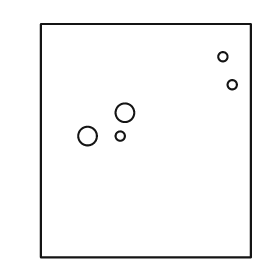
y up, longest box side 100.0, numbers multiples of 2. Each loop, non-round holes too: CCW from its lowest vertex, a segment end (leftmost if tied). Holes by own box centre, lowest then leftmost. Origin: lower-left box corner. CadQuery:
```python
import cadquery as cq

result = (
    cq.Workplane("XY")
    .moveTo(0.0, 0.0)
    .lineTo(90.0, 0.0)
    .lineTo(90.0, 100.0)
    .lineTo(0.0, 100.0)
    .close()
    .moveTo(20.0, 52.0)
    .circle(4.0)
    .moveTo(34.0, 52.0)
    .circle(2.0)
    .moveTo(36.0, 62.0)
    .circle(4.0)
    .moveTo(82.0, 74.0)
    .circle(2.0)
    .moveTo(78.0, 86.0)
    .circle(2.0)
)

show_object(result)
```